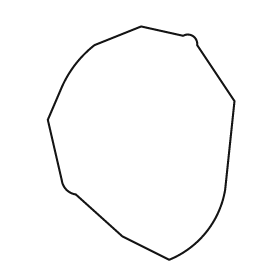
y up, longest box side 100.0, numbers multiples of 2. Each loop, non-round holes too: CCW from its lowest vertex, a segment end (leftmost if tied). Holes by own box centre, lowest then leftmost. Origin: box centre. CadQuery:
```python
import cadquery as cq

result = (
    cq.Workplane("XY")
    .moveTo(12.0, -50.0)
    .threePointArc((28.0, -38.0), (36.0, -20.0))
    .lineTo(40.0, 18.0)
    .lineTo(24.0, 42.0)
    .threePointArc((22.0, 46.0), (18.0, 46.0))
    .lineTo(0.0, 50.0)
    .lineTo(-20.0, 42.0)
    .threePointArc((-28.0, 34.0), (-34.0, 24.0))
    .lineTo(-40.0, 10.0)
    .lineTo(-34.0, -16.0)
    .threePointArc((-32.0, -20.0), (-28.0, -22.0))
    .lineTo(-8.0, -40.0)
    .close()
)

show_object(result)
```